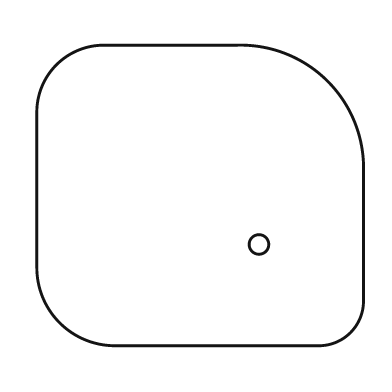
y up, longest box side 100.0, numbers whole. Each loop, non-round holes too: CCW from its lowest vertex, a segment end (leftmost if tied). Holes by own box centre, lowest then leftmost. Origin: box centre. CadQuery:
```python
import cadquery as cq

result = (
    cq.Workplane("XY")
    .moveTo(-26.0, -46.0)
    .lineTo(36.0, -46.0)
    .threePointArc((46.0, -42.0), (50.0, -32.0))
    .lineTo(50.0, 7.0)
    .threePointArc((39.0, 35.0), (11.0, 46.0))
    .lineTo(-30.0, 46.0)
    .threePointArc((-44.0, 40.0), (-50.0, 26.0))
    .lineTo(-50.0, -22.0)
    .threePointArc((-43.0, -39.0), (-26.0, -46.0))
    .close()
    .moveTo(18.0, -15.0)
    .circle(3.0)
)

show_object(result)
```